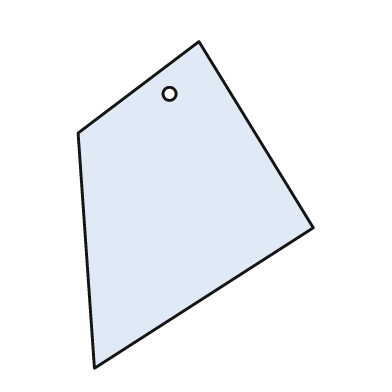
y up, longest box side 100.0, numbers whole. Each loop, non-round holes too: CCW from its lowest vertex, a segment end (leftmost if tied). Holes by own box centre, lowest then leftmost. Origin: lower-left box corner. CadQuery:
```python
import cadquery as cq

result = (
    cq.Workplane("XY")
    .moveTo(5.0, 0.0)
    .lineTo(72.0, 43.0)
    .lineTo(37.0, 100.0)
    .lineTo(0.0, 72.0)
    .close()
    .moveTo(28.0, 84.0)
    .circle(2.0)
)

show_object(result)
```